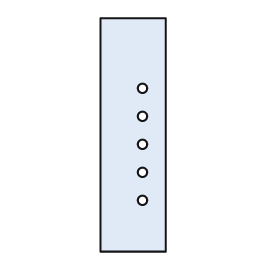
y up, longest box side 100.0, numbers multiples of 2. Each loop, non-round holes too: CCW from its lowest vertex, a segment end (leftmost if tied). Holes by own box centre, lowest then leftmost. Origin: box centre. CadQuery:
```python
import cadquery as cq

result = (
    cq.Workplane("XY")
    .moveTo(-14.0, -50.0)
    .lineTo(14.0, -50.0)
    .lineTo(14.0, 50.0)
    .lineTo(-14.0, 50.0)
    .close()
    .moveTo(4.0, -28.0)
    .circle(2.0)
    .moveTo(4.0, -16.0)
    .circle(2.0)
    .moveTo(4.0, -4.0)
    .circle(2.0)
    .moveTo(4.0, 8.0)
    .circle(2.0)
    .moveTo(4.0, 20.0)
    .circle(2.0)
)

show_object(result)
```